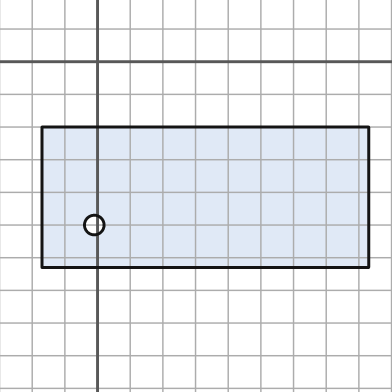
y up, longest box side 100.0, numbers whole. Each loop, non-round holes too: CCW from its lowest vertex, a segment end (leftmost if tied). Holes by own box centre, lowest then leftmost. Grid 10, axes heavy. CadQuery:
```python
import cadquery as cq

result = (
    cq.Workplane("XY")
    .moveTo(-17.0, -63.0)
    .lineTo(83.0, -63.0)
    .lineTo(83.0, -20.0)
    .lineTo(-17.0, -20.0)
    .close()
    .moveTo(-1.0, -50.0)
    .circle(3.0)
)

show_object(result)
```